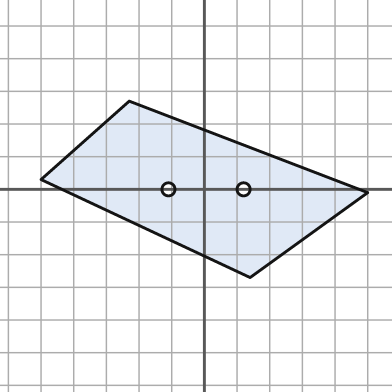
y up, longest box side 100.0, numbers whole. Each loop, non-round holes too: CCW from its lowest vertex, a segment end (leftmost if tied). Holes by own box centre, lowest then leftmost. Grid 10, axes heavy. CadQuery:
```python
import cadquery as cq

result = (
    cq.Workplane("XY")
    .moveTo(14.0, -27.0)
    .lineTo(50.0, -1.0)
    .lineTo(-23.0, 27.0)
    .lineTo(-50.0, 3.0)
    .close()
    .moveTo(-11.0, 0.0)
    .circle(2.0)
    .moveTo(12.0, 0.0)
    .circle(2.0)
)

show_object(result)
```